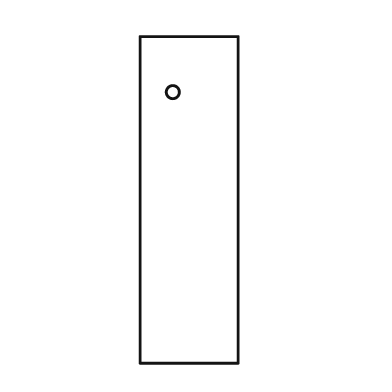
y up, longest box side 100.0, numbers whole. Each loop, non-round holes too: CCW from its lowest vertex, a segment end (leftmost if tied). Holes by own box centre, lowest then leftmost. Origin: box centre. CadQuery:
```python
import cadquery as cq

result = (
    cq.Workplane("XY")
    .moveTo(-15.0, -50.0)
    .lineTo(15.0, -50.0)
    .lineTo(15.0, 50.0)
    .lineTo(-15.0, 50.0)
    .close()
    .moveTo(-5.0, 33.0)
    .circle(2.0)
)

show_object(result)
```